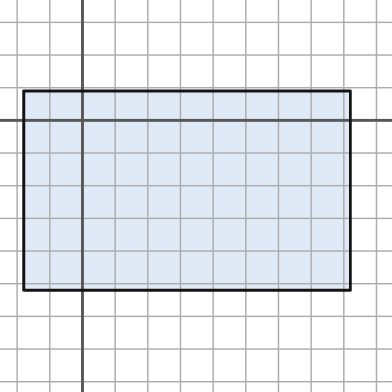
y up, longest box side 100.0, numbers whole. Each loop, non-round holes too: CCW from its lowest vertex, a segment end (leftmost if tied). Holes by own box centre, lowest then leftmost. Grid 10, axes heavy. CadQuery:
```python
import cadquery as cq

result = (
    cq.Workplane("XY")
    .moveTo(-18.0, -52.0)
    .lineTo(82.0, -52.0)
    .lineTo(82.0, 9.0)
    .lineTo(-18.0, 9.0)
    .close()
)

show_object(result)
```